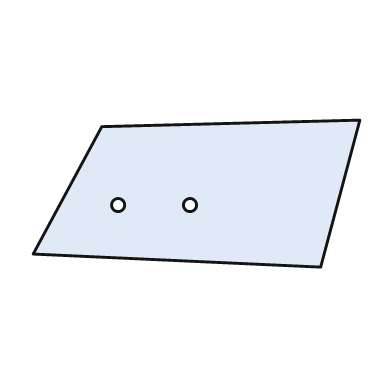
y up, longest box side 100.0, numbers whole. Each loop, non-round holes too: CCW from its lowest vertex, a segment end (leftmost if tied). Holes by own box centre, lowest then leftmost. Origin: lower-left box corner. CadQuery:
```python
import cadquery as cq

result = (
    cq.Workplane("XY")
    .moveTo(88.0, 0.0)
    .lineTo(100.0, 45.0)
    .lineTo(21.0, 43.0)
    .lineTo(0.0, 4.0)
    .close()
    .moveTo(26.0, 19.0)
    .circle(2.0)
    .moveTo(48.0, 19.0)
    .circle(2.0)
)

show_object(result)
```